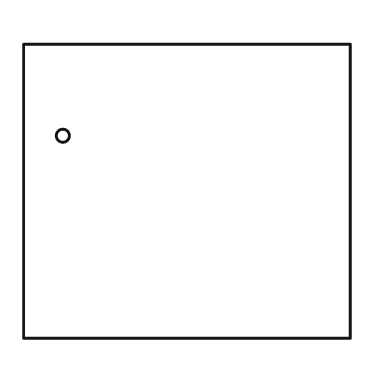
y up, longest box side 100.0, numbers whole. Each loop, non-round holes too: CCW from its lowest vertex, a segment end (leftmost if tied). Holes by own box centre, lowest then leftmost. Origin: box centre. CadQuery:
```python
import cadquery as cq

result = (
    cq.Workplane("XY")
    .moveTo(-50.0, -45.0)
    .lineTo(50.0, -45.0)
    .lineTo(50.0, 45.0)
    .lineTo(-50.0, 45.0)
    .close()
    .moveTo(-38.0, 17.0)
    .circle(2.0)
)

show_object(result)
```